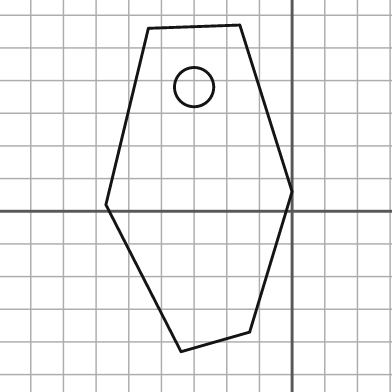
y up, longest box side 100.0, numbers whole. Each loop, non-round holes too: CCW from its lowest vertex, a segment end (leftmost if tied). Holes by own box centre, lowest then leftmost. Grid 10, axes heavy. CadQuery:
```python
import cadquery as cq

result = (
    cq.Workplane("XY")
    .moveTo(-34.0, -43.0)
    .lineTo(-13.0, -37.0)
    .lineTo(0.0, 6.0)
    .lineTo(-16.0, 57.0)
    .lineTo(-44.0, 56.0)
    .lineTo(-57.0, 2.0)
    .close()
    .moveTo(-30.0, 38.0)
    .circle(6.0)
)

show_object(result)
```